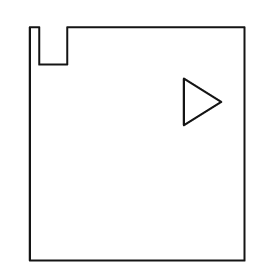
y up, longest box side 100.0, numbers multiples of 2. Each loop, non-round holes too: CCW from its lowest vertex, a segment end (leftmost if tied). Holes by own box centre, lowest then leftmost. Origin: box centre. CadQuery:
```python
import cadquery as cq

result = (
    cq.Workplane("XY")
    .moveTo(-46.0, -50.0)
    .lineTo(46.0, -50.0)
    .lineTo(46.0, 50.0)
    .lineTo(-30.0, 50.0)
    .lineTo(-30.0, 34.0)
    .lineTo(-42.0, 34.0)
    .lineTo(-42.0, 50.0)
    .lineTo(-46.0, 50.0)
    .close()
    .moveTo(20.0, 8.0)
    .lineTo(36.0, 18.0)
    .lineTo(20.0, 28.0)
    .close()
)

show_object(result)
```